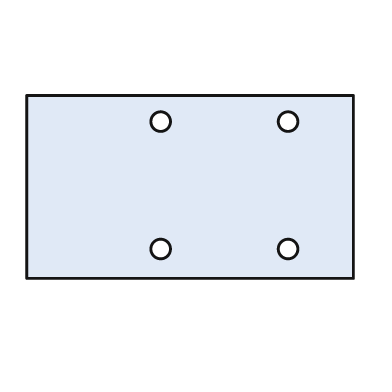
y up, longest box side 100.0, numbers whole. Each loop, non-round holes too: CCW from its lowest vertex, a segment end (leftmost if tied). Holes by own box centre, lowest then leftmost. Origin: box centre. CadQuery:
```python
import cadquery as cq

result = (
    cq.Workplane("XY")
    .moveTo(-50.0, -28.0)
    .lineTo(50.0, -28.0)
    .lineTo(50.0, 28.0)
    .lineTo(-50.0, 28.0)
    .close()
    .moveTo(-9.0, -19.0)
    .circle(3.0)
    .moveTo(30.0, -19.0)
    .circle(3.0)
    .moveTo(-9.0, 20.0)
    .circle(3.0)
    .moveTo(30.0, 20.0)
    .circle(3.0)
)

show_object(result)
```